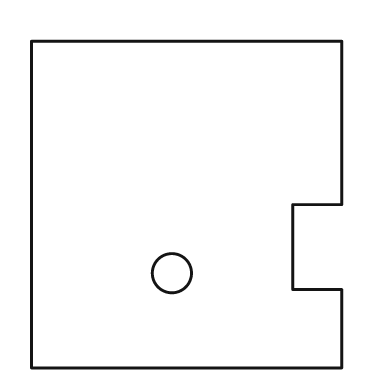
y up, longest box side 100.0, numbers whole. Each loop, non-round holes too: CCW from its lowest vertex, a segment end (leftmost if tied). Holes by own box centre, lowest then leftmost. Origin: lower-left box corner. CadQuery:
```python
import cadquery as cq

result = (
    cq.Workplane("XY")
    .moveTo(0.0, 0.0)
    .lineTo(95.0, 0.0)
    .lineTo(95.0, 24.0)
    .lineTo(80.0, 24.0)
    .lineTo(80.0, 50.0)
    .lineTo(95.0, 50.0)
    .lineTo(95.0, 100.0)
    .lineTo(0.0, 100.0)
    .close()
    .moveTo(43.0, 29.0)
    .circle(6.0)
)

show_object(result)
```